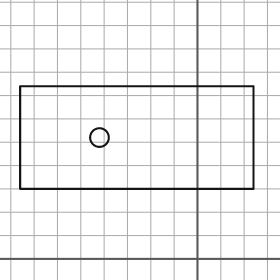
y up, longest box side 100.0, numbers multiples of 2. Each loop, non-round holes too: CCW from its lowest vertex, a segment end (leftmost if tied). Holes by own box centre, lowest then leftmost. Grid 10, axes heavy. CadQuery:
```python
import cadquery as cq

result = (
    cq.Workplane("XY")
    .moveTo(-76.0, 30.0)
    .lineTo(24.0, 30.0)
    .lineTo(24.0, 74.0)
    .lineTo(-76.0, 74.0)
    .close()
    .moveTo(-42.0, 52.0)
    .circle(4.0)
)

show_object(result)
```